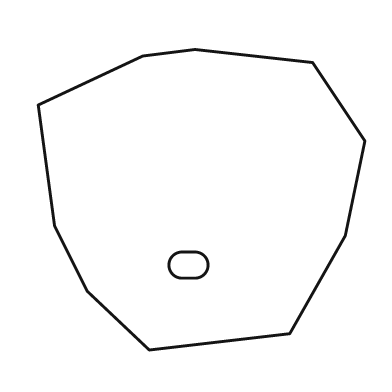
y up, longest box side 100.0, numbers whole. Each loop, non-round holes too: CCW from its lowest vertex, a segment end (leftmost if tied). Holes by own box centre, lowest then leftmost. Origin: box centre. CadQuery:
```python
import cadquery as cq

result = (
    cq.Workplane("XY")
    .moveTo(-16.0, -46.0)
    .lineTo(27.0, -41.0)
    .lineTo(44.0, -11.0)
    .lineTo(50.0, 18.0)
    .lineTo(34.0, 42.0)
    .lineTo(-2.0, 46.0)
    .lineTo(-18.0, 44.0)
    .lineTo(-50.0, 29.0)
    .lineTo(-45.0, -8.0)
    .lineTo(-35.0, -28.0)
    .close()
    .moveTo(-6.0, -24.0)
    .lineTo(-2.0, -24.0)
    .threePointArc((2.0, -20.0), (-2.0, -16.0))
    .lineTo(-6.0, -16.0)
    .threePointArc((-10.0, -20.0), (-6.0, -24.0))
    .close()
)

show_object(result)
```